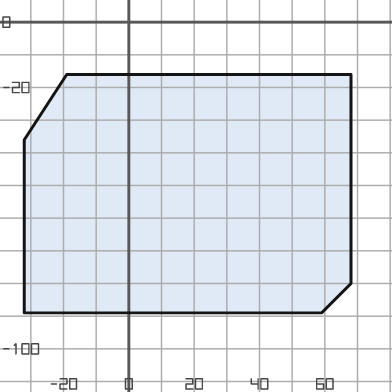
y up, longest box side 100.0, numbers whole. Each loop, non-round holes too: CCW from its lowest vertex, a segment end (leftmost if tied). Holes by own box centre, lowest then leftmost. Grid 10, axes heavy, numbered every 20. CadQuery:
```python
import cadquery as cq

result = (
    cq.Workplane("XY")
    .moveTo(-32.0, -89.0)
    .lineTo(59.0, -89.0)
    .lineTo(68.0, -80.0)
    .lineTo(68.0, -16.0)
    .lineTo(-19.0, -16.0)
    .lineTo(-32.0, -36.0)
    .close()
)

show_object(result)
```